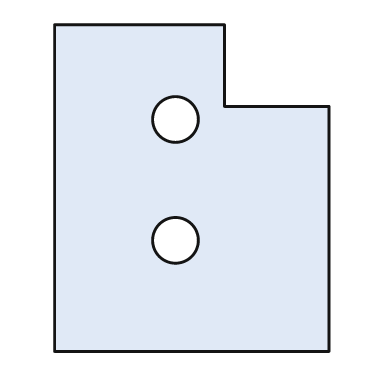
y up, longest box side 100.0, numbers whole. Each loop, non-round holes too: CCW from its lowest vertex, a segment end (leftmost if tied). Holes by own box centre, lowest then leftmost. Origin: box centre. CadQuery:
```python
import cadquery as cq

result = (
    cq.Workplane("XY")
    .moveTo(-42.0, -50.0)
    .lineTo(42.0, -50.0)
    .lineTo(42.0, 25.0)
    .lineTo(10.0, 25.0)
    .lineTo(10.0, 50.0)
    .lineTo(-42.0, 50.0)
    .close()
    .moveTo(-5.0, -16.0)
    .circle(7.0)
    .moveTo(-5.0, 21.0)
    .circle(7.0)
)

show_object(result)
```